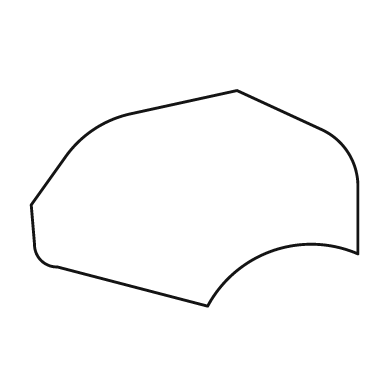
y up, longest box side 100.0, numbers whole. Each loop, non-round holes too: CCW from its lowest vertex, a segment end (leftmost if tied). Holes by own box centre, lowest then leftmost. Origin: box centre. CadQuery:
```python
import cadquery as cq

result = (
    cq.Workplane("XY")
    .moveTo(4.0, -33.0)
    .threePointArc((24.0, -16.0), (50.0, -17.0))
    .lineTo(50.0, 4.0)
    .threePointArc((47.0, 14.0), (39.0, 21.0))
    .lineTo(13.0, 33.0)
    .lineTo(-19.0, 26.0)
    .threePointArc((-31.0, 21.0), (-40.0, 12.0))
    .lineTo(-50.0, -2.0)
    .lineTo(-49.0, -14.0)
    .threePointArc((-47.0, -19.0), (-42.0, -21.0))
    .close()
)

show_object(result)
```